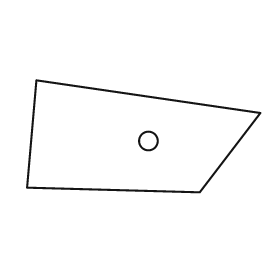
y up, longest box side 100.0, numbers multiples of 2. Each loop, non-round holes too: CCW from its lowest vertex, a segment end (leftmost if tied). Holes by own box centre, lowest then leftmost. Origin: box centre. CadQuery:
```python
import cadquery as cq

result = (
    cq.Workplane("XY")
    .moveTo(24.0, -24.0)
    .lineTo(50.0, 10.0)
    .lineTo(-46.0, 24.0)
    .lineTo(-50.0, -22.0)
    .close()
    .moveTo(2.0, -2.0)
    .circle(4.0)
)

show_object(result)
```